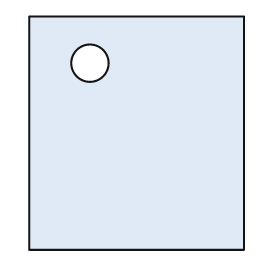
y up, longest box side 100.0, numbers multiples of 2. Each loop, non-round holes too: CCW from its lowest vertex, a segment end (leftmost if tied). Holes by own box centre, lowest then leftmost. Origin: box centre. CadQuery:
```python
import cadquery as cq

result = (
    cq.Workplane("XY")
    .moveTo(-46.0, -50.0)
    .lineTo(46.0, -50.0)
    .lineTo(46.0, 50.0)
    .lineTo(-46.0, 50.0)
    .close()
    .moveTo(-20.0, 30.0)
    .circle(8.0)
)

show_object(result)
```